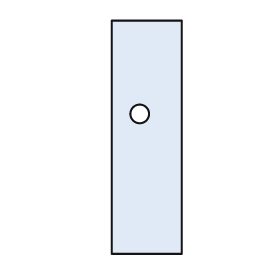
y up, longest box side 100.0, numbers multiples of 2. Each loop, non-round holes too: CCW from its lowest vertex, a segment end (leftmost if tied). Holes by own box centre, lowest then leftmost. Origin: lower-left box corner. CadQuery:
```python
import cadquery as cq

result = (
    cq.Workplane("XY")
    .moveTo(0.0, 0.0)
    .lineTo(30.0, 0.0)
    .lineTo(30.0, 100.0)
    .lineTo(0.0, 100.0)
    .close()
    .moveTo(12.0, 60.0)
    .circle(4.0)
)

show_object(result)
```